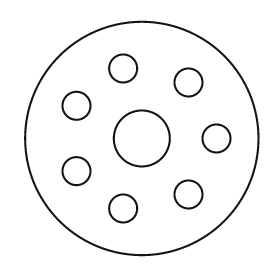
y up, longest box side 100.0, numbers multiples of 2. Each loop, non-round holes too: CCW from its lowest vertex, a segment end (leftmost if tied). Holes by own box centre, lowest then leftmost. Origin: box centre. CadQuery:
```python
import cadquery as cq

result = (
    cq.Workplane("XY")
    .moveTo(0.0, 0.0)
    .circle(50.0)
    .moveTo(-8.0, -30.0)
    .circle(6.0)
    .moveTo(20.0, -24.0)
    .circle(6.0)
    .moveTo(-28.0, -14.0)
    .circle(6.0)
    .moveTo(0.0, 0.0)
    .circle(12.0)
    .moveTo(32.0, 0.0)
    .circle(6.0)
    .moveTo(-28.0, 14.0)
    .circle(6.0)
    .moveTo(20.0, 24.0)
    .circle(6.0)
    .moveTo(-8.0, 30.0)
    .circle(6.0)
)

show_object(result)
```